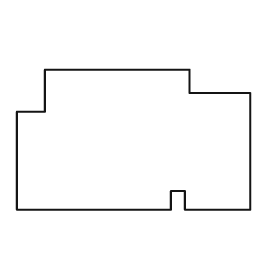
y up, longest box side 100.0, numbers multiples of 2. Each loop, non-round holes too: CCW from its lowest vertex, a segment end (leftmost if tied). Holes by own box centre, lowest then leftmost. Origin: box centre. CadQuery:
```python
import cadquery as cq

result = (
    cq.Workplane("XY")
    .moveTo(-50.0, -30.0)
    .lineTo(16.0, -30.0)
    .lineTo(16.0, -22.0)
    .lineTo(22.0, -22.0)
    .lineTo(22.0, -30.0)
    .lineTo(50.0, -30.0)
    .lineTo(50.0, 20.0)
    .lineTo(24.0, 20.0)
    .lineTo(24.0, 30.0)
    .lineTo(-38.0, 30.0)
    .lineTo(-38.0, 12.0)
    .lineTo(-50.0, 12.0)
    .close()
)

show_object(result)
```